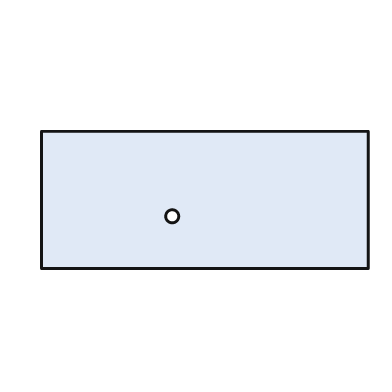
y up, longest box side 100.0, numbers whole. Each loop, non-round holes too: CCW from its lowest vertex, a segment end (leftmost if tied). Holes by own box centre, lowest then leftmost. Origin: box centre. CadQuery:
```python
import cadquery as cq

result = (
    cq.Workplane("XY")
    .moveTo(-50.0, -21.0)
    .lineTo(50.0, -21.0)
    .lineTo(50.0, 21.0)
    .lineTo(-50.0, 21.0)
    .close()
    .moveTo(-10.0, -5.0)
    .circle(2.0)
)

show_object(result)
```